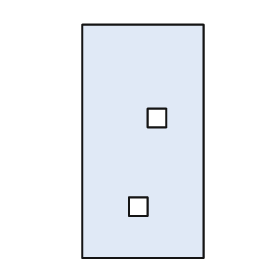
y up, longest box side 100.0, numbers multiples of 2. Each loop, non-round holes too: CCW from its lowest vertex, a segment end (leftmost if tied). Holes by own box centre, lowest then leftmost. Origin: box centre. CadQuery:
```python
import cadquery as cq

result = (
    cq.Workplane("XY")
    .moveTo(-26.0, -50.0)
    .lineTo(26.0, -50.0)
    .lineTo(26.0, 50.0)
    .lineTo(-26.0, 50.0)
    .close()
    .moveTo(-6.0, -32.0)
    .lineTo(2.0, -32.0)
    .lineTo(2.0, -24.0)
    .lineTo(-6.0, -24.0)
    .close()
    .moveTo(2.0, 6.0)
    .lineTo(10.0, 6.0)
    .lineTo(10.0, 14.0)
    .lineTo(2.0, 14.0)
    .close()
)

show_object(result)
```